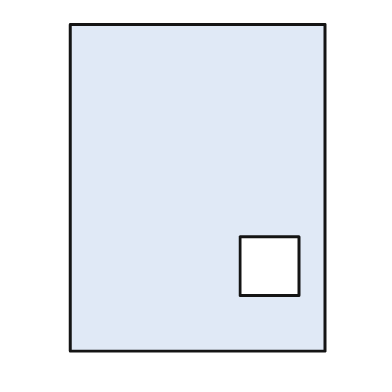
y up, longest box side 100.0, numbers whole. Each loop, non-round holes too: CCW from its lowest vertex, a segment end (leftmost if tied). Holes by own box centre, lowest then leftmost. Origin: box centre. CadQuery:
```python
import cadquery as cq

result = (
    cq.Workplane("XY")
    .moveTo(-39.0, -50.0)
    .lineTo(39.0, -50.0)
    .lineTo(39.0, 50.0)
    .lineTo(-39.0, 50.0)
    .close()
    .moveTo(13.0, -33.0)
    .lineTo(31.0, -33.0)
    .lineTo(31.0, -15.0)
    .lineTo(13.0, -15.0)
    .close()
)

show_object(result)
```